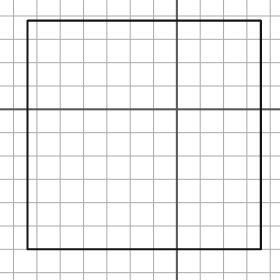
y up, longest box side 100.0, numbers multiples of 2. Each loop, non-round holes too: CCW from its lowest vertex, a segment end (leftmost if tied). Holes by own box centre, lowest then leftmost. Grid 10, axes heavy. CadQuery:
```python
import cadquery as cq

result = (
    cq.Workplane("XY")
    .moveTo(-64.0, -60.0)
    .lineTo(36.0, -60.0)
    .lineTo(36.0, 38.0)
    .lineTo(-64.0, 38.0)
    .close()
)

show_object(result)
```